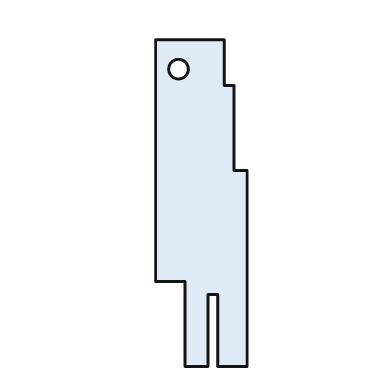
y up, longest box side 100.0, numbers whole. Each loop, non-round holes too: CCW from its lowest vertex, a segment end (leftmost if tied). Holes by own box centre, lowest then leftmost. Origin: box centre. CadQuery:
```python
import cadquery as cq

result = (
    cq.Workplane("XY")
    .moveTo(-5.0, -50.0)
    .lineTo(2.0, -50.0)
    .lineTo(2.0, -28.0)
    .lineTo(5.0, -28.0)
    .lineTo(5.0, -50.0)
    .lineTo(14.0, -50.0)
    .lineTo(14.0, 10.0)
    .lineTo(10.0, 10.0)
    .lineTo(10.0, 36.0)
    .lineTo(7.0, 36.0)
    .lineTo(7.0, 50.0)
    .lineTo(-14.0, 50.0)
    .lineTo(-14.0, -24.0)
    .lineTo(-5.0, -24.0)
    .close()
    .moveTo(-7.0, 41.0)
    .circle(3.0)
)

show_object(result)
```